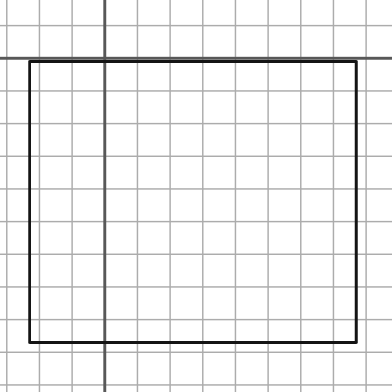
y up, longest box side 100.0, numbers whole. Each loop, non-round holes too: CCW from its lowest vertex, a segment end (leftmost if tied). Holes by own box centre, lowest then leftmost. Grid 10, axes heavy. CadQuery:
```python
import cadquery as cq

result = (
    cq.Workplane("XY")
    .moveTo(-23.0, -87.0)
    .lineTo(77.0, -87.0)
    .lineTo(77.0, -1.0)
    .lineTo(-23.0, -1.0)
    .close()
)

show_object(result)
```